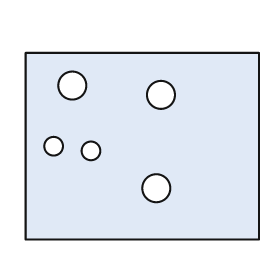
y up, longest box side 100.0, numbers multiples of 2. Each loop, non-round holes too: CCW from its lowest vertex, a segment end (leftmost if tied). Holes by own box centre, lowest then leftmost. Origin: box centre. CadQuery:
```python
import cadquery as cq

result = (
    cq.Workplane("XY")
    .moveTo(-50.0, -40.0)
    .lineTo(50.0, -40.0)
    .lineTo(50.0, 40.0)
    .lineTo(-50.0, 40.0)
    .close()
    .moveTo(6.0, -18.0)
    .circle(6.0)
    .moveTo(-22.0, -2.0)
    .circle(4.0)
    .moveTo(-38.0, 0.0)
    .circle(4.0)
    .moveTo(8.0, 22.0)
    .circle(6.0)
    .moveTo(-30.0, 26.0)
    .circle(6.0)
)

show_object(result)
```